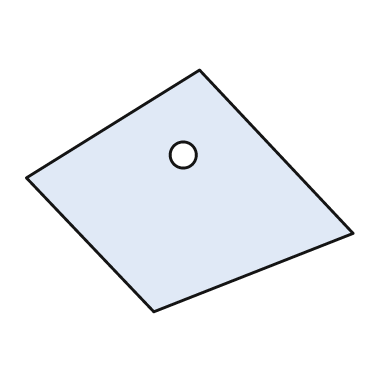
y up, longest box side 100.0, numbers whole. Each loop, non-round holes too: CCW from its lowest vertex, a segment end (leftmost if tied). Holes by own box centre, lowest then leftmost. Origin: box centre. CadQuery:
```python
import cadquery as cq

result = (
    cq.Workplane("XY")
    .moveTo(-11.0, -37.0)
    .lineTo(50.0, -13.0)
    .lineTo(3.0, 37.0)
    .lineTo(-50.0, 4.0)
    .close()
    .moveTo(-2.0, 11.0)
    .circle(4.0)
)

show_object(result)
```